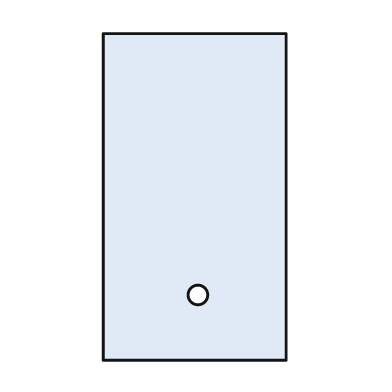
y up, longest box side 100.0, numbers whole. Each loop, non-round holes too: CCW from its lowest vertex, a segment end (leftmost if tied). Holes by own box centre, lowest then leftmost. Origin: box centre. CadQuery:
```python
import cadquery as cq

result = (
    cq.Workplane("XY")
    .moveTo(-28.0, -50.0)
    .lineTo(28.0, -50.0)
    .lineTo(28.0, 50.0)
    .lineTo(-28.0, 50.0)
    .close()
    .moveTo(1.0, -30.0)
    .circle(3.0)
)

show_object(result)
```